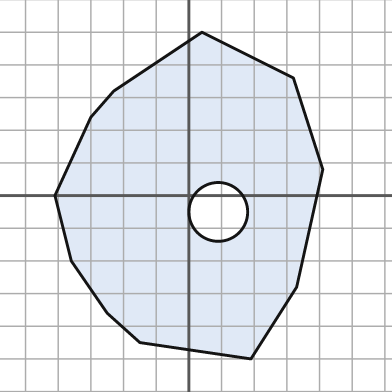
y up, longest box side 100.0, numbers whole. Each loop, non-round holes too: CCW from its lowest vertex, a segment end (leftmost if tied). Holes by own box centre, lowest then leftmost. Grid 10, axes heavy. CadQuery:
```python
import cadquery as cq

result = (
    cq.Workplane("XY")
    .moveTo(19.0, -50.0)
    .lineTo(33.0, -28.0)
    .lineTo(41.0, 8.0)
    .lineTo(32.0, 36.0)
    .lineTo(4.0, 50.0)
    .lineTo(-23.0, 32.0)
    .lineTo(-30.0, 24.0)
    .lineTo(-41.0, 0.0)
    .lineTo(-36.0, -20.0)
    .lineTo(-25.0, -36.0)
    .lineTo(-15.0, -45.0)
    .close()
    .moveTo(9.0, -5.0)
    .circle(9.0)
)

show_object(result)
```